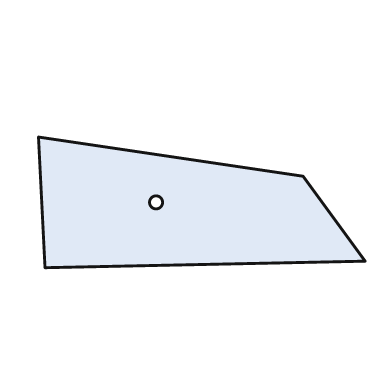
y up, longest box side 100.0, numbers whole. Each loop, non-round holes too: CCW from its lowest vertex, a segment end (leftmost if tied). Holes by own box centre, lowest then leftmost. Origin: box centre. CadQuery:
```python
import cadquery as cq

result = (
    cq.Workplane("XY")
    .moveTo(-48.0, -20.0)
    .lineTo(50.0, -18.0)
    .lineTo(31.0, 8.0)
    .lineTo(-50.0, 20.0)
    .close()
    .moveTo(-14.0, 0.0)
    .circle(2.0)
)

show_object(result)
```